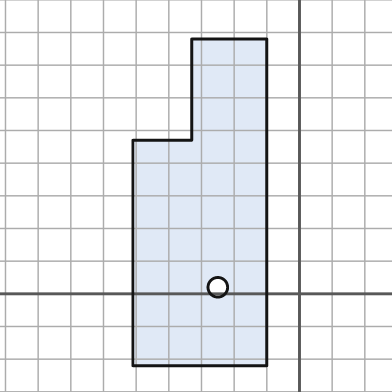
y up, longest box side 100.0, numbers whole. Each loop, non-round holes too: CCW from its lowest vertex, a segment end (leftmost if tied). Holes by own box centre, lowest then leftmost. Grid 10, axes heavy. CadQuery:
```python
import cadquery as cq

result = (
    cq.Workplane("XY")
    .moveTo(-51.0, -22.0)
    .lineTo(-10.0, -22.0)
    .lineTo(-10.0, 78.0)
    .lineTo(-33.0, 78.0)
    .lineTo(-33.0, 47.0)
    .lineTo(-51.0, 47.0)
    .close()
    .moveTo(-25.0, 2.0)
    .circle(3.0)
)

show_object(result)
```